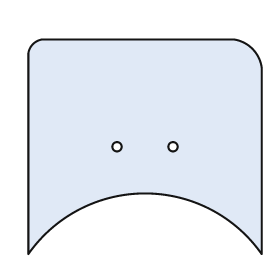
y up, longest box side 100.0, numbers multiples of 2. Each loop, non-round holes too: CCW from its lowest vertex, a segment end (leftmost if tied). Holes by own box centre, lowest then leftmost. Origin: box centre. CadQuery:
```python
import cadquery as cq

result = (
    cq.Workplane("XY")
    .moveTo(-50.0, -46.0)
    .threePointArc((0.0, -20.0), (50.0, -46.0))
    .lineTo(50.0, 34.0)
    .threePointArc((46.0, 42.0), (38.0, 46.0))
    .lineTo(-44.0, 46.0)
    .threePointArc((-48.0, 44.0), (-50.0, 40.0))
    .close()
    .moveTo(-12.0, 0.0)
    .circle(2.0)
    .moveTo(12.0, 0.0)
    .circle(2.0)
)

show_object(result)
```